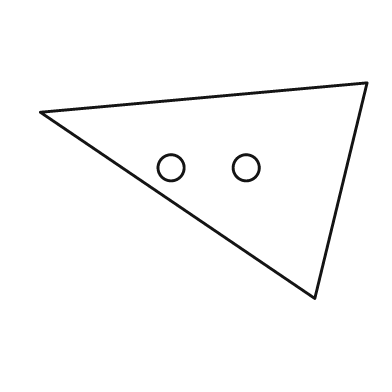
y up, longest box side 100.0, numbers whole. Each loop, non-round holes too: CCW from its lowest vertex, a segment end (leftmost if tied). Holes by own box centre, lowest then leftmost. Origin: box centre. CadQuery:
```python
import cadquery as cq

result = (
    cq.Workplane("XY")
    .moveTo(34.0, -33.0)
    .lineTo(50.0, 33.0)
    .lineTo(-50.0, 24.0)
    .close()
    .moveTo(-10.0, 7.0)
    .circle(4.0)
    .moveTo(13.0, 7.0)
    .circle(4.0)
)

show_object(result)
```